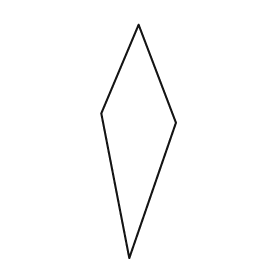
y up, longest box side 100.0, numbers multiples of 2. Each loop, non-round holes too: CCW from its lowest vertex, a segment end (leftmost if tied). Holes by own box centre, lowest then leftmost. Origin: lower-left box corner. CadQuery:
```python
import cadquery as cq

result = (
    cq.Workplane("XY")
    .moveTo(12.0, 0.0)
    .lineTo(32.0, 58.0)
    .lineTo(16.0, 100.0)
    .lineTo(0.0, 62.0)
    .close()
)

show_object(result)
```